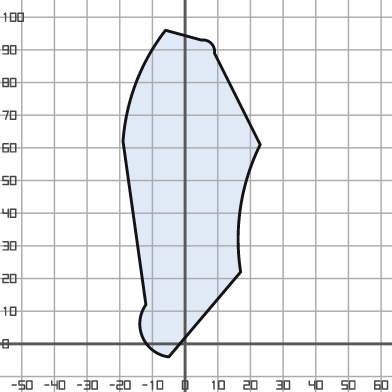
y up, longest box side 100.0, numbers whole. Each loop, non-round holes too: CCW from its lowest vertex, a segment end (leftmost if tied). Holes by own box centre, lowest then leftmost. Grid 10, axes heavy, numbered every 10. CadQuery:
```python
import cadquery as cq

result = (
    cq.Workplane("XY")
    .moveTo(-5.0, -4.0)
    .lineTo(17.0, 22.0)
    .threePointArc((17.0, 42.0), (23.0, 61.0))
    .lineTo(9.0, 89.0)
    .threePointArc((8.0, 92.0), (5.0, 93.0))
    .lineTo(-6.0, 96.0)
    .threePointArc((-15.0, 80.0), (-19.0, 62.0))
    .lineTo(-12.0, 12.0)
    .threePointArc((-13.0, 2.0), (-5.0, -4.0))
    .close()
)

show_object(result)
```